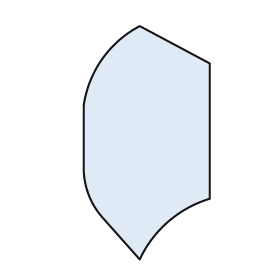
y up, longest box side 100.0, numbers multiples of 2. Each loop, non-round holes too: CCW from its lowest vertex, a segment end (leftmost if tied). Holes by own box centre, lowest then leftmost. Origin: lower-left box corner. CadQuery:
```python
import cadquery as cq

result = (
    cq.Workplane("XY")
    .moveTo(24.0, 0.0)
    .threePointArc((36.0, 16.0), (54.0, 26.0))
    .lineTo(54.0, 84.0)
    .lineTo(24.0, 100.0)
    .threePointArc((8.0, 86.0), (0.0, 66.0))
    .lineTo(0.0, 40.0)
    .threePointArc((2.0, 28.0), (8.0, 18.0))
    .close()
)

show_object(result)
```